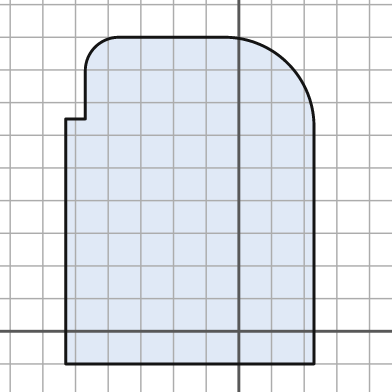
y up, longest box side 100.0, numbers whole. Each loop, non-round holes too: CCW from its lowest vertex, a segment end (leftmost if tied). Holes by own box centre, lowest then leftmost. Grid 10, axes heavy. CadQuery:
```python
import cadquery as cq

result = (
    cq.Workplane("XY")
    .moveTo(-53.0, -10.0)
    .lineTo(23.0, -10.0)
    .lineTo(23.0, 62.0)
    .threePointArc((15.0, 82.0), (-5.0, 90.0))
    .lineTo(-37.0, 90.0)
    .threePointArc((-44.0, 87.0), (-47.0, 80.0))
    .lineTo(-47.0, 65.0)
    .lineTo(-53.0, 65.0)
    .close()
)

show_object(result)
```